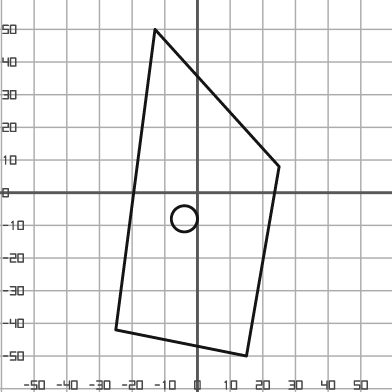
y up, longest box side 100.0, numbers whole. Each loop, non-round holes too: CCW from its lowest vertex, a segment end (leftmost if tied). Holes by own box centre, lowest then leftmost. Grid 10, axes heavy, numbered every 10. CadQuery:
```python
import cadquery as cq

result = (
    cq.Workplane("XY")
    .moveTo(15.0, -50.0)
    .lineTo(25.0, 8.0)
    .lineTo(-13.0, 50.0)
    .lineTo(-25.0, -42.0)
    .close()
    .moveTo(-4.0, -8.0)
    .circle(4.0)
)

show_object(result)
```